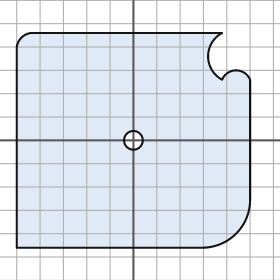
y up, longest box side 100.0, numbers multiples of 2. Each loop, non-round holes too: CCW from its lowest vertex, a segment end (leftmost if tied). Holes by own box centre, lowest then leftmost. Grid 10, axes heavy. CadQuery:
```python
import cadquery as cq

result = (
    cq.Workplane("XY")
    .moveTo(-50.0, -46.0)
    .lineTo(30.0, -46.0)
    .threePointArc((44.0, -40.0), (50.0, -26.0))
    .lineTo(50.0, 26.0)
    .threePointArc((44.0, 30.0), (38.0, 26.0))
    .threePointArc((32.0, 36.0), (38.0, 46.0))
    .lineTo(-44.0, 46.0)
    .threePointArc((-48.0, 44.0), (-50.0, 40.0))
    .close()
    .moveTo(0.0, 0.0)
    .circle(4.0)
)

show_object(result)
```